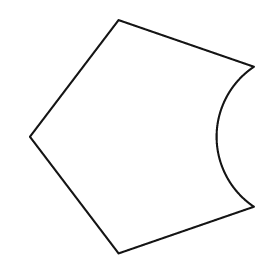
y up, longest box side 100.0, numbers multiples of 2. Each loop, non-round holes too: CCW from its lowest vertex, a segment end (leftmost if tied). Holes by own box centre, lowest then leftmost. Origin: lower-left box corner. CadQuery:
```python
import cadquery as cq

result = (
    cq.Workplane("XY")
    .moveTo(38.0, 0.0)
    .lineTo(96.0, 20.0)
    .threePointArc((80.0, 50.0), (96.0, 80.0))
    .lineTo(38.0, 100.0)
    .lineTo(0.0, 50.0)
    .close()
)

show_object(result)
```